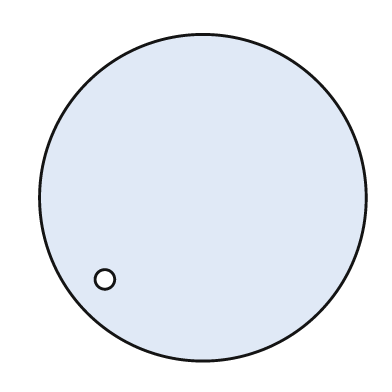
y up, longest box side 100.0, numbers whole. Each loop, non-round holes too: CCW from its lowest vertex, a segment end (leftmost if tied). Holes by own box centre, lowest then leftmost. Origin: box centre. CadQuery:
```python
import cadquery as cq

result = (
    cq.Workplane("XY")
    .moveTo(0.0, 0.0)
    .circle(50.0)
    .moveTo(-30.0, -25.0)
    .circle(3.0)
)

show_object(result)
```